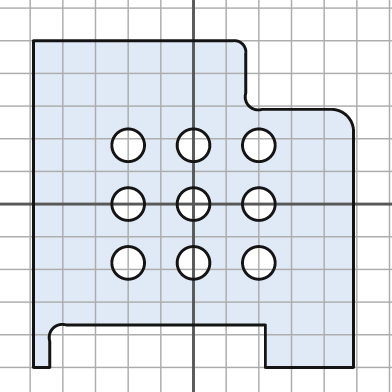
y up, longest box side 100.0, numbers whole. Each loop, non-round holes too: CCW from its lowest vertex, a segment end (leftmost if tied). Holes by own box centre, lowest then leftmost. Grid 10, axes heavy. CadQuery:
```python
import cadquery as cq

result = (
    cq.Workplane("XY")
    .moveTo(-49.0, -50.0)
    .lineTo(-44.0, -50.0)
    .lineTo(-44.0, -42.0)
    .threePointArc((-43.0, -38.0), (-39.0, -37.0))
    .lineTo(22.0, -37.0)
    .lineTo(22.0, -50.0)
    .lineTo(49.0, -50.0)
    .lineTo(49.0, 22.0)
    .threePointArc((47.0, 27.0), (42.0, 29.0))
    .lineTo(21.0, 29.0)
    .threePointArc((17.0, 30.0), (16.0, 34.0))
    .lineTo(16.0, 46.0)
    .threePointArc((15.0, 49.0), (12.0, 50.0))
    .lineTo(-49.0, 50.0)
    .close()
    .moveTo(-20.0, -18.0)
    .circle(5.0)
    .moveTo(0.0, -18.0)
    .circle(5.0)
    .moveTo(20.0, -18.0)
    .circle(5.0)
    .moveTo(-20.0, 0.0)
    .circle(5.0)
    .moveTo(0.0, 0.0)
    .circle(5.0)
    .moveTo(20.0, 0.0)
    .circle(5.0)
    .moveTo(-20.0, 18.0)
    .circle(5.0)
    .moveTo(0.0, 18.0)
    .circle(5.0)
    .moveTo(20.0, 18.0)
    .circle(5.0)
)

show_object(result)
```